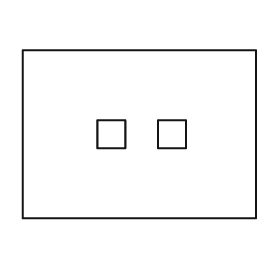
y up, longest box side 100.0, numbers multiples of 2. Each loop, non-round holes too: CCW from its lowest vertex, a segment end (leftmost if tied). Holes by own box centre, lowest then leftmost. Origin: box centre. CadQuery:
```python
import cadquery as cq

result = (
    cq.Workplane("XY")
    .moveTo(-50.0, -36.0)
    .lineTo(50.0, -36.0)
    .lineTo(50.0, 36.0)
    .lineTo(-50.0, 36.0)
    .close()
    .moveTo(-18.0, -6.0)
    .lineTo(-6.0, -6.0)
    .lineTo(-6.0, 6.0)
    .lineTo(-18.0, 6.0)
    .close()
    .moveTo(8.0, -6.0)
    .lineTo(20.0, -6.0)
    .lineTo(20.0, 6.0)
    .lineTo(8.0, 6.0)
    .close()
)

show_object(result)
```